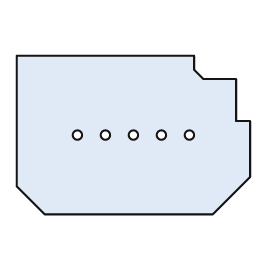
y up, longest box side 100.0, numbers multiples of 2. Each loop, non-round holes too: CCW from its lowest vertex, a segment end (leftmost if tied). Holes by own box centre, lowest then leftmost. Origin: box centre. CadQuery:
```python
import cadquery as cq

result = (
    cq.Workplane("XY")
    .moveTo(-38.0, -34.0)
    .lineTo(34.0, -34.0)
    .lineTo(50.0, -18.0)
    .lineTo(50.0, 6.0)
    .lineTo(44.0, 6.0)
    .lineTo(44.0, 24.0)
    .lineTo(30.0, 24.0)
    .lineTo(26.0, 28.0)
    .lineTo(26.0, 34.0)
    .lineTo(-50.0, 34.0)
    .lineTo(-50.0, -22.0)
    .close()
    .moveTo(-24.0, 0.0)
    .circle(2.0)
    .moveTo(-12.0, 0.0)
    .circle(2.0)
    .moveTo(0.0, 0.0)
    .circle(2.0)
    .moveTo(12.0, 0.0)
    .circle(2.0)
    .moveTo(24.0, 0.0)
    .circle(2.0)
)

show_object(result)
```